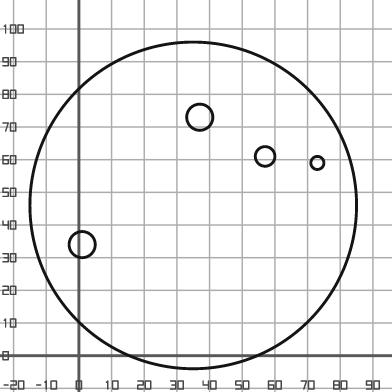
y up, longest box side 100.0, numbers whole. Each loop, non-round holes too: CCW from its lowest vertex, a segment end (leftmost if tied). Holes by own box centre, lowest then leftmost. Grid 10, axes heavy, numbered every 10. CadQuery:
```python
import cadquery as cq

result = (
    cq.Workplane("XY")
    .moveTo(35.0, 46.0)
    .circle(50.0)
    .moveTo(1.0, 34.0)
    .circle(4.0)
    .moveTo(73.0, 59.0)
    .circle(2.0)
    .moveTo(57.0, 61.0)
    .circle(3.0)
    .moveTo(37.0, 73.0)
    .circle(4.0)
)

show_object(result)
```